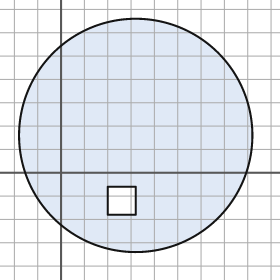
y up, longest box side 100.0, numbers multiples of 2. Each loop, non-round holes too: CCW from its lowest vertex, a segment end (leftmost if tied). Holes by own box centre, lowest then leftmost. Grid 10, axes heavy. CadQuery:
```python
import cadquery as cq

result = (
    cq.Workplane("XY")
    .moveTo(32.0, 16.0)
    .circle(50.0)
    .moveTo(20.0, -18.0)
    .lineTo(32.0, -18.0)
    .lineTo(32.0, -6.0)
    .lineTo(20.0, -6.0)
    .close()
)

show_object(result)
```